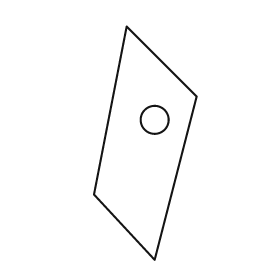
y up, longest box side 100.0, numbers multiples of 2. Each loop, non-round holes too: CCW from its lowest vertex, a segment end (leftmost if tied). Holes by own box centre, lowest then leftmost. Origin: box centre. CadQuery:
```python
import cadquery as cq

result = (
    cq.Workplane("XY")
    .moveTo(4.0, -50.0)
    .lineTo(22.0, 20.0)
    .lineTo(-8.0, 50.0)
    .lineTo(-22.0, -22.0)
    .close()
    .moveTo(4.0, 10.0)
    .circle(6.0)
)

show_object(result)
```